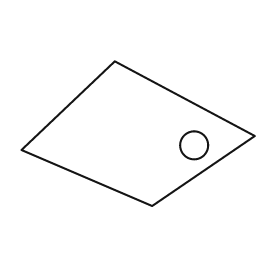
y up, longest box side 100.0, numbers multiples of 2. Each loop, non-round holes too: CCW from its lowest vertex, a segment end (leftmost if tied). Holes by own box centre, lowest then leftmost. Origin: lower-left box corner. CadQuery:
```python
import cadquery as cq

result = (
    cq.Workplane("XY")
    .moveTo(56.0, 0.0)
    .lineTo(100.0, 30.0)
    .lineTo(40.0, 62.0)
    .lineTo(0.0, 24.0)
    .close()
    .moveTo(74.0, 26.0)
    .circle(6.0)
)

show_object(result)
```